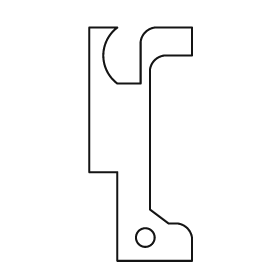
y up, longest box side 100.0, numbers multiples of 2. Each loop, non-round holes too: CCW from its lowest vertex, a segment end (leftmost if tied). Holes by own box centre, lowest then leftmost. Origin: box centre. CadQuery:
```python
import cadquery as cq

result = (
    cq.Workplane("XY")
    .moveTo(-10.0, -50.0)
    .lineTo(22.0, -50.0)
    .lineTo(22.0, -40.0)
    .threePointArc((20.0, -36.0), (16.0, -34.0))
    .lineTo(12.0, -34.0)
    .lineTo(4.0, -28.0)
    .lineTo(4.0, 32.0)
    .threePointArc((6.0, 36.0), (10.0, 38.0))
    .lineTo(22.0, 38.0)
    .lineTo(22.0, 50.0)
    .lineTo(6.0, 50.0)
    .threePointArc((2.0, 48.0), (0.0, 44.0))
    .lineTo(0.0, 26.0)
    .lineTo(-10.0, 26.0)
    .threePointArc((-16.0, 38.0), (-10.0, 50.0))
    .lineTo(-22.0, 50.0)
    .lineTo(-22.0, -12.0)
    .lineTo(-10.0, -12.0)
    .close()
    .moveTo(2.0, -40.0)
    .circle(4.0)
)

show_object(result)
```